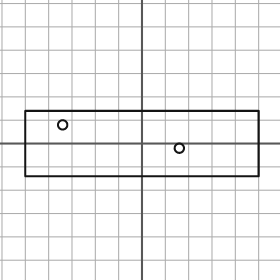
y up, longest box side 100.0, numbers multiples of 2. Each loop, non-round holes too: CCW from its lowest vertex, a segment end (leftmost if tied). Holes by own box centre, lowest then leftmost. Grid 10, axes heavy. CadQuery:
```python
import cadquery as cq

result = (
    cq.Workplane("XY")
    .moveTo(-50.0, -14.0)
    .lineTo(50.0, -14.0)
    .lineTo(50.0, 14.0)
    .lineTo(-50.0, 14.0)
    .close()
    .moveTo(16.0, -2.0)
    .circle(2.0)
    .moveTo(-34.0, 8.0)
    .circle(2.0)
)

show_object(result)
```